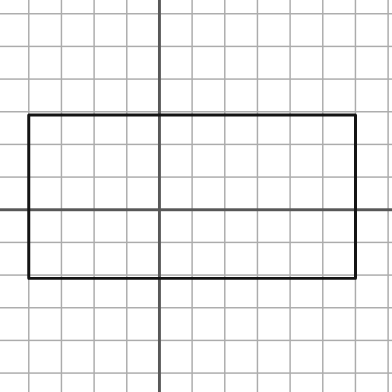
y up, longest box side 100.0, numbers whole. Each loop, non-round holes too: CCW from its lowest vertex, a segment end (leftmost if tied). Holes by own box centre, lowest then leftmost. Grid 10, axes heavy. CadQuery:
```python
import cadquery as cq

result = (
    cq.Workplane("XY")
    .moveTo(-40.0, -21.0)
    .lineTo(60.0, -21.0)
    .lineTo(60.0, 29.0)
    .lineTo(-40.0, 29.0)
    .close()
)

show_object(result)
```